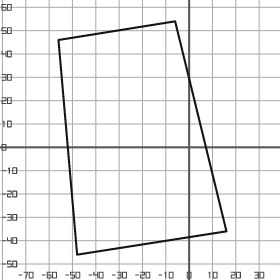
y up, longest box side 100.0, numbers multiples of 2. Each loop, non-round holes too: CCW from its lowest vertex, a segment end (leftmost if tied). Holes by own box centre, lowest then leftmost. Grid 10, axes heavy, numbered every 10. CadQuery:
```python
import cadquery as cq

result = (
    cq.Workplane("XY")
    .moveTo(-48.0, -46.0)
    .lineTo(16.0, -36.0)
    .lineTo(-6.0, 54.0)
    .lineTo(-56.0, 46.0)
    .close()
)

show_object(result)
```